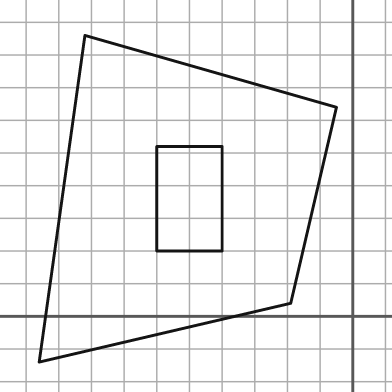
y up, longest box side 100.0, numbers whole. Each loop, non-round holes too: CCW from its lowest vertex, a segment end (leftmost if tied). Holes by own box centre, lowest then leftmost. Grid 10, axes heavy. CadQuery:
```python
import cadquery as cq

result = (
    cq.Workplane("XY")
    .moveTo(-96.0, -14.0)
    .lineTo(-19.0, 4.0)
    .lineTo(-5.0, 64.0)
    .lineTo(-82.0, 86.0)
    .close()
    .moveTo(-60.0, 20.0)
    .lineTo(-40.0, 20.0)
    .lineTo(-40.0, 52.0)
    .lineTo(-60.0, 52.0)
    .close()
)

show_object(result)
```